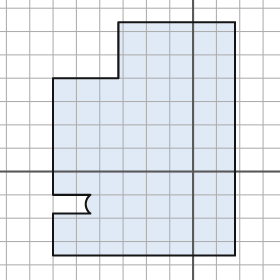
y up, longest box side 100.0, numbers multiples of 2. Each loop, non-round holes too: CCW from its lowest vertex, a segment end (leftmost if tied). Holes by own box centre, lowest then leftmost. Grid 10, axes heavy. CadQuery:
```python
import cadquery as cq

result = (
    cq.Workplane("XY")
    .moveTo(-60.0, -36.0)
    .lineTo(18.0, -36.0)
    .lineTo(18.0, 64.0)
    .lineTo(-32.0, 64.0)
    .lineTo(-32.0, 40.0)
    .lineTo(-60.0, 40.0)
    .lineTo(-60.0, -10.0)
    .lineTo(-44.0, -10.0)
    .threePointArc((-46.0, -14.0), (-44.0, -18.0))
    .lineTo(-60.0, -18.0)
    .close()
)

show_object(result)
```